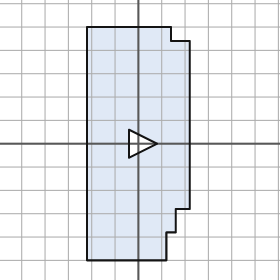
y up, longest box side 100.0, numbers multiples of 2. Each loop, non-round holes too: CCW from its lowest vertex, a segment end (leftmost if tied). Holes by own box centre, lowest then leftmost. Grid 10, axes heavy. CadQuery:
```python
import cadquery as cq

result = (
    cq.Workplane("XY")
    .moveTo(-22.0, -50.0)
    .lineTo(12.0, -50.0)
    .lineTo(12.0, -38.0)
    .lineTo(16.0, -38.0)
    .lineTo(16.0, -28.0)
    .lineTo(22.0, -28.0)
    .lineTo(22.0, 44.0)
    .lineTo(14.0, 44.0)
    .lineTo(14.0, 50.0)
    .lineTo(-22.0, 50.0)
    .close()
    .moveTo(-4.0, -6.0)
    .lineTo(8.0, 0.0)
    .lineTo(-4.0, 6.0)
    .close()
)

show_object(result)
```